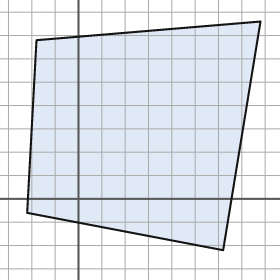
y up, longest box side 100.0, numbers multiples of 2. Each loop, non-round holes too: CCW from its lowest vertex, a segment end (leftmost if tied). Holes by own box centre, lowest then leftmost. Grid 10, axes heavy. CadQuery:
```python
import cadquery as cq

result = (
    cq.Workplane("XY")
    .moveTo(62.0, -22.0)
    .lineTo(78.0, 76.0)
    .lineTo(-18.0, 68.0)
    .lineTo(-22.0, -6.0)
    .close()
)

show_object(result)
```